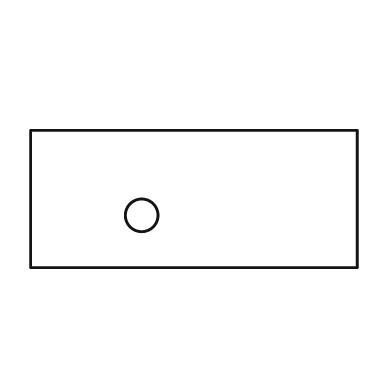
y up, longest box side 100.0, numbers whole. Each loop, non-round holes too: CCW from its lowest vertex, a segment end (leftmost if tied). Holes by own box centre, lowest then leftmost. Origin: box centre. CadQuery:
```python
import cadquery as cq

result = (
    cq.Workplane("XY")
    .moveTo(-50.0, -21.0)
    .lineTo(50.0, -21.0)
    .lineTo(50.0, 21.0)
    .lineTo(-50.0, 21.0)
    .close()
    .moveTo(-16.0, -5.0)
    .circle(5.0)
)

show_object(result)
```